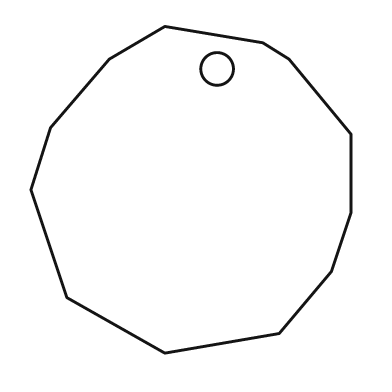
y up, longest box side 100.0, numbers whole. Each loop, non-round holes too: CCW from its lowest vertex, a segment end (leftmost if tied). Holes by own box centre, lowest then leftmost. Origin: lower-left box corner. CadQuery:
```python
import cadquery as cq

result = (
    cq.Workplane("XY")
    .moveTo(41.0, 0.0)
    .lineTo(76.0, 6.0)
    .lineTo(92.0, 25.0)
    .lineTo(98.0, 43.0)
    .lineTo(98.0, 67.0)
    .lineTo(79.0, 90.0)
    .lineTo(71.0, 95.0)
    .lineTo(41.0, 100.0)
    .lineTo(24.0, 90.0)
    .lineTo(6.0, 69.0)
    .lineTo(0.0, 50.0)
    .lineTo(11.0, 17.0)
    .close()
    .moveTo(57.0, 87.0)
    .circle(5.0)
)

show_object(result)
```